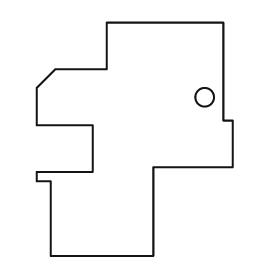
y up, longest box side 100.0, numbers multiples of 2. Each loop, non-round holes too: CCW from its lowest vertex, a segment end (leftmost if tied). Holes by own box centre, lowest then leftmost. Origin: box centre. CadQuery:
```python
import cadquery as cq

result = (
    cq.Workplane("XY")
    .moveTo(-36.0, -50.0)
    .lineTo(8.0, -50.0)
    .lineTo(8.0, -12.0)
    .lineTo(42.0, -12.0)
    .lineTo(42.0, 8.0)
    .lineTo(38.0, 8.0)
    .lineTo(38.0, 50.0)
    .lineTo(-12.0, 50.0)
    .lineTo(-12.0, 30.0)
    .lineTo(-34.0, 30.0)
    .lineTo(-42.0, 22.0)
    .lineTo(-42.0, 6.0)
    .lineTo(-18.0, 6.0)
    .lineTo(-18.0, -14.0)
    .lineTo(-42.0, -14.0)
    .lineTo(-42.0, -18.0)
    .lineTo(-36.0, -18.0)
    .close()
    .moveTo(30.0, 18.0)
    .circle(4.0)
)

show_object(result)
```